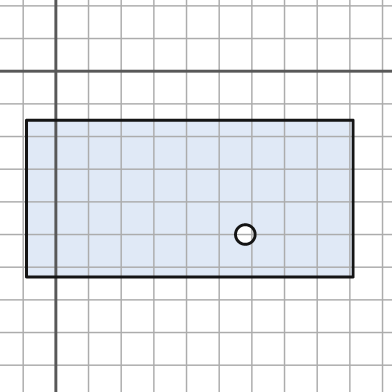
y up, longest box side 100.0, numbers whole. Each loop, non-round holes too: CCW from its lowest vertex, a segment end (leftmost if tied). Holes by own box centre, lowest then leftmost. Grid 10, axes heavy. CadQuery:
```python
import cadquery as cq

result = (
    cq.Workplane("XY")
    .moveTo(-9.0, -63.0)
    .lineTo(91.0, -63.0)
    .lineTo(91.0, -15.0)
    .lineTo(-9.0, -15.0)
    .close()
    .moveTo(58.0, -50.0)
    .circle(3.0)
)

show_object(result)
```